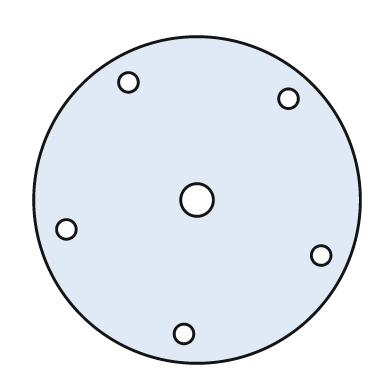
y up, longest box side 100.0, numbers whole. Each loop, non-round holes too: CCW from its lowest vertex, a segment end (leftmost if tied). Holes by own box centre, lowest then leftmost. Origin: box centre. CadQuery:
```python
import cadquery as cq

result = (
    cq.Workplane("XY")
    .moveTo(0.0, 0.0)
    .circle(50.0)
    .moveTo(-4.0, -41.0)
    .circle(3.0)
    .moveTo(38.0, -17.0)
    .circle(3.0)
    .moveTo(-40.0, -9.0)
    .circle(3.0)
    .moveTo(0.0, 0.0)
    .circle(5.0)
    .moveTo(28.0, 31.0)
    .circle(3.0)
    .moveTo(-21.0, 36.0)
    .circle(3.0)
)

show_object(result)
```